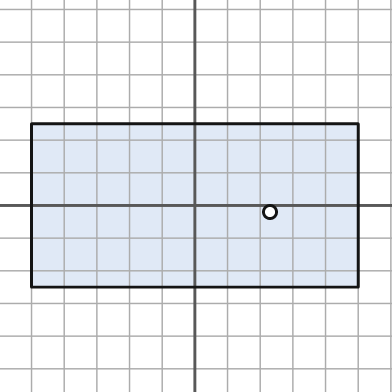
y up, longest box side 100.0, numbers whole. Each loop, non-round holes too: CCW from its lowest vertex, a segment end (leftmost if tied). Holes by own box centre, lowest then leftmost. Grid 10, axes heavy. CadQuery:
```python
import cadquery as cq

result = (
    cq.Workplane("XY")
    .moveTo(-50.0, -25.0)
    .lineTo(50.0, -25.0)
    .lineTo(50.0, 25.0)
    .lineTo(-50.0, 25.0)
    .close()
    .moveTo(23.0, -2.0)
    .circle(2.0)
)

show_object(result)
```